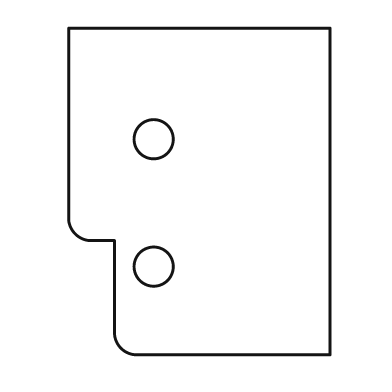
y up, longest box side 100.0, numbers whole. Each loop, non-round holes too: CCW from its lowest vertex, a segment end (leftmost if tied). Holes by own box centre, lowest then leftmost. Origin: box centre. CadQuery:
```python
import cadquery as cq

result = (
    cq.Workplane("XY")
    .moveTo(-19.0, -50.0)
    .lineTo(40.0, -50.0)
    .lineTo(40.0, 50.0)
    .lineTo(-40.0, 50.0)
    .lineTo(-40.0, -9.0)
    .threePointArc((-38.0, -13.0), (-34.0, -15.0))
    .lineTo(-26.0, -15.0)
    .lineTo(-26.0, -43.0)
    .threePointArc((-24.0, -48.0), (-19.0, -50.0))
    .close()
    .moveTo(-14.0, -23.0)
    .circle(6.0)
    .moveTo(-14.0, 16.0)
    .circle(6.0)
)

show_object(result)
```